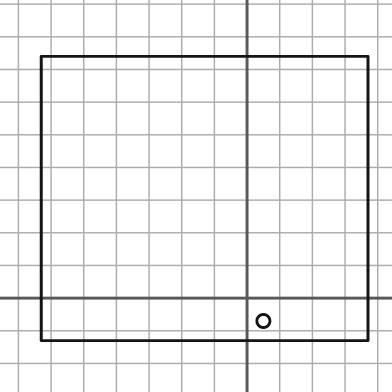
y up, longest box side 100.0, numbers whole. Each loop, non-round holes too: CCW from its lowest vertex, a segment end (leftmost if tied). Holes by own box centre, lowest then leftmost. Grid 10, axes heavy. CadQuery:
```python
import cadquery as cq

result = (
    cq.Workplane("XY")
    .moveTo(-63.0, -13.0)
    .lineTo(37.0, -13.0)
    .lineTo(37.0, 74.0)
    .lineTo(-63.0, 74.0)
    .close()
    .moveTo(5.0, -7.0)
    .circle(2.0)
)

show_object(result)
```